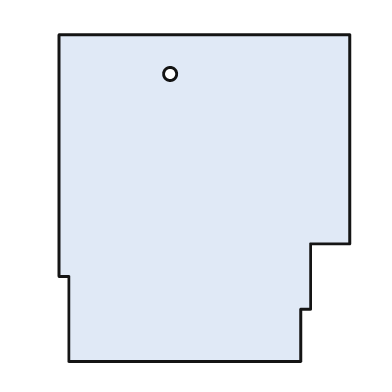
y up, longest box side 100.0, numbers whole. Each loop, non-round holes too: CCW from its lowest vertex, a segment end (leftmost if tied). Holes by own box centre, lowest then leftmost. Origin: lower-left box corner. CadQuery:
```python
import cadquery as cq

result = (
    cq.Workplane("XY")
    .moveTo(3.0, 0.0)
    .lineTo(74.0, 0.0)
    .lineTo(74.0, 16.0)
    .lineTo(77.0, 16.0)
    .lineTo(77.0, 36.0)
    .lineTo(89.0, 36.0)
    .lineTo(89.0, 100.0)
    .lineTo(0.0, 100.0)
    .lineTo(0.0, 26.0)
    .lineTo(3.0, 26.0)
    .close()
    .moveTo(34.0, 88.0)
    .circle(2.0)
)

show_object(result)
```